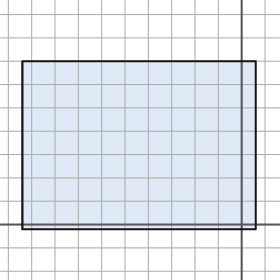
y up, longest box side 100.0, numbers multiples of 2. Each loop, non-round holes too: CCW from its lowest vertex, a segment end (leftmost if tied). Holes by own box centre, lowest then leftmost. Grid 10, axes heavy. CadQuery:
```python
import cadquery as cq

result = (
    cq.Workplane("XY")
    .moveTo(-94.0, -2.0)
    .lineTo(6.0, -2.0)
    .lineTo(6.0, 70.0)
    .lineTo(-94.0, 70.0)
    .close()
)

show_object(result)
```